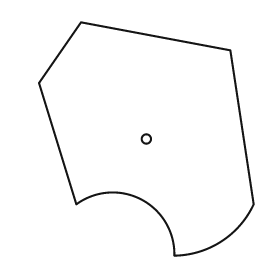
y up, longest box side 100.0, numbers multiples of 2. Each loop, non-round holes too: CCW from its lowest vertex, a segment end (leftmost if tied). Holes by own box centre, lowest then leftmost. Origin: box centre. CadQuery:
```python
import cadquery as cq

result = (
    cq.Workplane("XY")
    .moveTo(12.0, -50.0)
    .threePointArc((32.0, -44.0), (46.0, -28.0))
    .lineTo(36.0, 38.0)
    .lineTo(-28.0, 50.0)
    .lineTo(-46.0, 24.0)
    .lineTo(-30.0, -28.0)
    .threePointArc((-2.0, -26.0), (12.0, -50.0))
    .close()
    .moveTo(0.0, 0.0)
    .circle(2.0)
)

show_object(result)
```